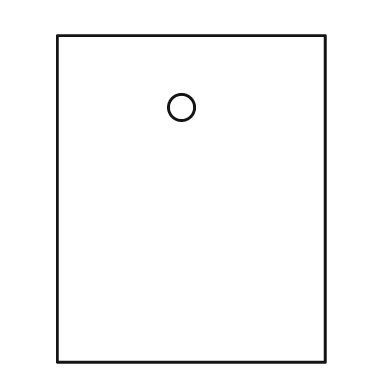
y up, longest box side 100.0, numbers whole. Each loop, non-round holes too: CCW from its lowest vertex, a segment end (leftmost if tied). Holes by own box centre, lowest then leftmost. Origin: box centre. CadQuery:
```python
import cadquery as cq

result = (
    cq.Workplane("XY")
    .moveTo(-41.0, -50.0)
    .lineTo(41.0, -50.0)
    .lineTo(41.0, 50.0)
    .lineTo(-41.0, 50.0)
    .close()
    .moveTo(-3.0, 28.0)
    .circle(4.0)
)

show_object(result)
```